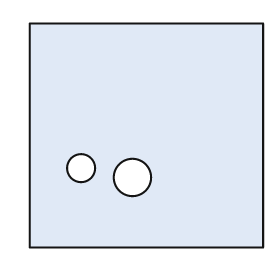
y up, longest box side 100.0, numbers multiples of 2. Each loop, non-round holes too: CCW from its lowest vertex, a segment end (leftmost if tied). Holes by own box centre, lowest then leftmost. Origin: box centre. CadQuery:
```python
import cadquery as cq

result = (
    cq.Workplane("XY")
    .moveTo(-50.0, -48.0)
    .lineTo(50.0, -48.0)
    .lineTo(50.0, 48.0)
    .lineTo(-50.0, 48.0)
    .close()
    .moveTo(-6.0, -18.0)
    .circle(8.0)
    .moveTo(-28.0, -14.0)
    .circle(6.0)
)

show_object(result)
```